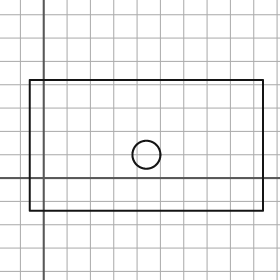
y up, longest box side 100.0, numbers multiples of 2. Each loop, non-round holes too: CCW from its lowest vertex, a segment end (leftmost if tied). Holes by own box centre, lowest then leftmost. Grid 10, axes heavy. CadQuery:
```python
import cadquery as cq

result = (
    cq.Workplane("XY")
    .moveTo(-6.0, -14.0)
    .lineTo(94.0, -14.0)
    .lineTo(94.0, 42.0)
    .lineTo(-6.0, 42.0)
    .close()
    .moveTo(44.0, 10.0)
    .circle(6.0)
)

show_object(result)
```